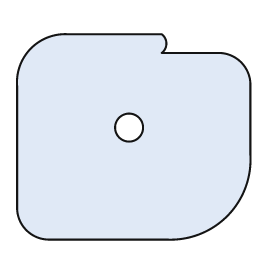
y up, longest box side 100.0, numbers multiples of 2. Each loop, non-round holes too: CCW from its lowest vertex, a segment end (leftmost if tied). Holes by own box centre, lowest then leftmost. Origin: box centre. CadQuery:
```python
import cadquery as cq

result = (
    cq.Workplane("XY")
    .moveTo(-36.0, -44.0)
    .lineTo(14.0, -44.0)
    .threePointArc((40.0, -34.0), (50.0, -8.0))
    .lineTo(50.0, 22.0)
    .threePointArc((46.0, 32.0), (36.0, 36.0))
    .lineTo(12.0, 36.0)
    .threePointArc((14.0, 40.0), (12.0, 44.0))
    .lineTo(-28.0, 44.0)
    .threePointArc((-44.0, 38.0), (-50.0, 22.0))
    .lineTo(-50.0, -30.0)
    .threePointArc((-46.0, -40.0), (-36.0, -44.0))
    .close()
    .moveTo(-2.0, 4.0)
    .circle(6.0)
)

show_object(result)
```